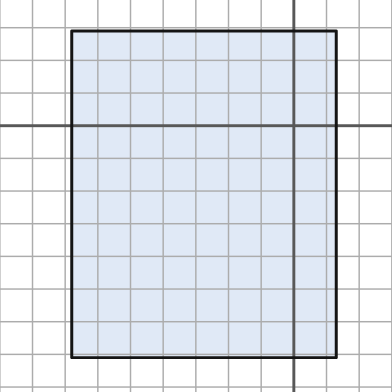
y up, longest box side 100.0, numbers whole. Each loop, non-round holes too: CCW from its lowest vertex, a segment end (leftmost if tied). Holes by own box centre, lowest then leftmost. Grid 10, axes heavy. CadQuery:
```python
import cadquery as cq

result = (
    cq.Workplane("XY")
    .moveTo(-68.0, -71.0)
    .lineTo(13.0, -71.0)
    .lineTo(13.0, 29.0)
    .lineTo(-68.0, 29.0)
    .close()
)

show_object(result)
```